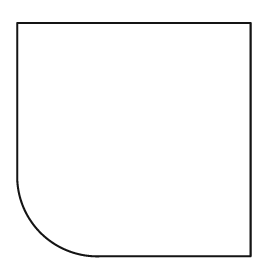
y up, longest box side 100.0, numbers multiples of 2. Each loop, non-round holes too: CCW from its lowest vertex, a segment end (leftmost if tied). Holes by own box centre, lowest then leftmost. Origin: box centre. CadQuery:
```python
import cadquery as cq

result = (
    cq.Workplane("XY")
    .moveTo(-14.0, -50.0)
    .lineTo(50.0, -50.0)
    .lineTo(50.0, 50.0)
    .lineTo(-50.0, 50.0)
    .lineTo(-50.0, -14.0)
    .threePointArc((-40.0, -40.0), (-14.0, -50.0))
    .close()
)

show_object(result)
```